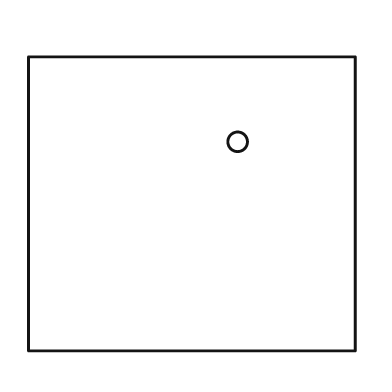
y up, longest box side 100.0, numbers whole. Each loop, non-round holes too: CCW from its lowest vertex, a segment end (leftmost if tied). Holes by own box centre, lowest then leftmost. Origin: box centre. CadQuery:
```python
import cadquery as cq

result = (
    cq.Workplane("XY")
    .moveTo(-50.0, -45.0)
    .lineTo(50.0, -45.0)
    .lineTo(50.0, 45.0)
    .lineTo(-50.0, 45.0)
    .close()
    .moveTo(14.0, 19.0)
    .circle(3.0)
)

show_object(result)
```